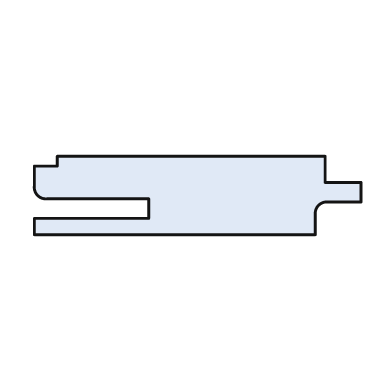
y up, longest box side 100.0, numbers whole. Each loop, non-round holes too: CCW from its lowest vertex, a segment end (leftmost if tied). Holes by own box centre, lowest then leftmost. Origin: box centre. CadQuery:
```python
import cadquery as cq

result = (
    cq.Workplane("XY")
    .moveTo(-50.0, -12.0)
    .lineTo(36.0, -12.0)
    .lineTo(36.0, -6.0)
    .threePointArc((37.0, -3.0), (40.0, -2.0))
    .lineTo(50.0, -2.0)
    .lineTo(50.0, 4.0)
    .lineTo(39.0, 4.0)
    .lineTo(39.0, 12.0)
    .lineTo(-43.0, 12.0)
    .lineTo(-43.0, 9.0)
    .lineTo(-50.0, 9.0)
    .lineTo(-50.0, 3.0)
    .threePointArc((-49.0, 0.0), (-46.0, -1.0))
    .lineTo(-15.0, -1.0)
    .lineTo(-15.0, -7.0)
    .lineTo(-50.0, -7.0)
    .close()
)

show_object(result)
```